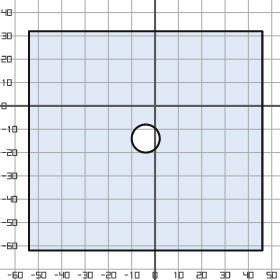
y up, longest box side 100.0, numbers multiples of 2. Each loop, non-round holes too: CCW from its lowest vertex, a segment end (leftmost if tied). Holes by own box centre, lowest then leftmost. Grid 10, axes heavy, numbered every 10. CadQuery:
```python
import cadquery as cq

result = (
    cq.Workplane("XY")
    .moveTo(-54.0, -62.0)
    .lineTo(46.0, -62.0)
    .lineTo(46.0, 32.0)
    .lineTo(-54.0, 32.0)
    .close()
    .moveTo(-4.0, -14.0)
    .circle(6.0)
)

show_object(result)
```